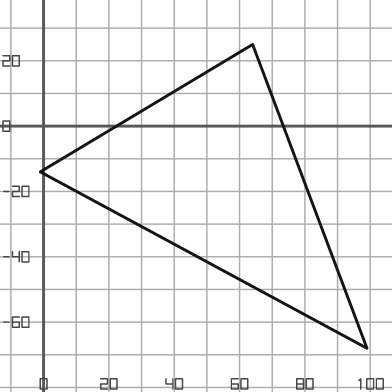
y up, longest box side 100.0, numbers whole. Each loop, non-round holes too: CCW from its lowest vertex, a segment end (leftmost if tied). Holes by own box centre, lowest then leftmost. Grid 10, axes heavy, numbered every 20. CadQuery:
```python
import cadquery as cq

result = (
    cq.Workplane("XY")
    .moveTo(99.0, -68.0)
    .lineTo(64.0, 25.0)
    .lineTo(-1.0, -14.0)
    .close()
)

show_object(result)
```